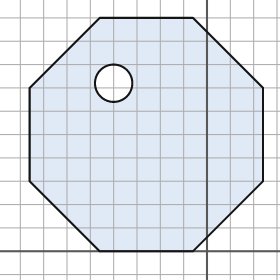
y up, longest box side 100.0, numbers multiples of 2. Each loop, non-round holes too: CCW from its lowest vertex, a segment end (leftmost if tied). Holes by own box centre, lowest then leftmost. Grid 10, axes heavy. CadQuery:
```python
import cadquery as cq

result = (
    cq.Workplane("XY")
    .moveTo(-46.0, 0.0)
    .lineTo(-6.0, 0.0)
    .lineTo(24.0, 30.0)
    .lineTo(24.0, 70.0)
    .lineTo(-6.0, 100.0)
    .lineTo(-46.0, 100.0)
    .lineTo(-76.0, 70.0)
    .lineTo(-76.0, 30.0)
    .close()
    .moveTo(-40.0, 72.0)
    .circle(8.0)
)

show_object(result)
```